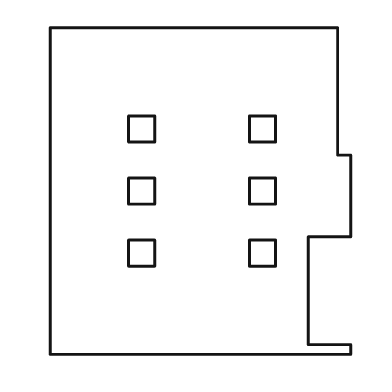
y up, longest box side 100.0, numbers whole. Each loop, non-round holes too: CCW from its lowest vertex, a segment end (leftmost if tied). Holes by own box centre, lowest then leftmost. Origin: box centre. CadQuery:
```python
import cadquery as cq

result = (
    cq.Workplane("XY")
    .moveTo(-46.0, -50.0)
    .lineTo(46.0, -50.0)
    .lineTo(46.0, -47.0)
    .lineTo(33.0, -47.0)
    .lineTo(33.0, -14.0)
    .lineTo(46.0, -14.0)
    .lineTo(46.0, 11.0)
    .lineTo(42.0, 11.0)
    .lineTo(42.0, 50.0)
    .lineTo(-46.0, 50.0)
    .close()
    .moveTo(-22.0, -23.0)
    .lineTo(-14.0, -23.0)
    .lineTo(-14.0, -15.0)
    .lineTo(-22.0, -15.0)
    .close()
    .moveTo(15.0, -23.0)
    .lineTo(23.0, -23.0)
    .lineTo(23.0, -15.0)
    .lineTo(15.0, -15.0)
    .close()
    .moveTo(-22.0, -4.0)
    .lineTo(-14.0, -4.0)
    .lineTo(-14.0, 4.0)
    .lineTo(-22.0, 4.0)
    .close()
    .moveTo(15.0, -4.0)
    .lineTo(23.0, -4.0)
    .lineTo(23.0, 4.0)
    .lineTo(15.0, 4.0)
    .close()
    .moveTo(-22.0, 15.0)
    .lineTo(-14.0, 15.0)
    .lineTo(-14.0, 23.0)
    .lineTo(-22.0, 23.0)
    .close()
    .moveTo(15.0, 15.0)
    .lineTo(23.0, 15.0)
    .lineTo(23.0, 23.0)
    .lineTo(15.0, 23.0)
    .close()
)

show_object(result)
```